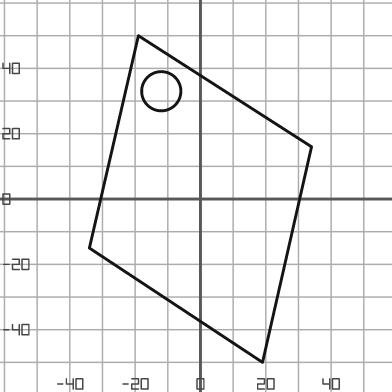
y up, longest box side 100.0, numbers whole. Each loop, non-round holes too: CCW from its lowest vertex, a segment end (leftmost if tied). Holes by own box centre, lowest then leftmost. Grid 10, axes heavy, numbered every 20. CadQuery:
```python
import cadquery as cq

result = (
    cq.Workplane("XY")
    .moveTo(19.0, -50.0)
    .lineTo(34.0, 16.0)
    .lineTo(-19.0, 50.0)
    .lineTo(-34.0, -15.0)
    .close()
    .moveTo(-12.0, 33.0)
    .circle(6.0)
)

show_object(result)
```